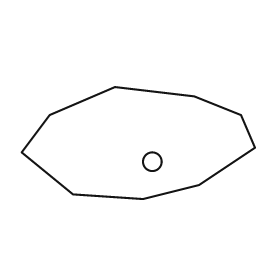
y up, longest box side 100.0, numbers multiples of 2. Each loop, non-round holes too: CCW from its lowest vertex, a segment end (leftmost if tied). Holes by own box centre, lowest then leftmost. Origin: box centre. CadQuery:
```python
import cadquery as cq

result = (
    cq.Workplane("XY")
    .moveTo(2.0, -24.0)
    .lineTo(26.0, -18.0)
    .lineTo(50.0, -2.0)
    .lineTo(44.0, 12.0)
    .lineTo(24.0, 20.0)
    .lineTo(-10.0, 24.0)
    .lineTo(-38.0, 12.0)
    .lineTo(-50.0, -4.0)
    .lineTo(-28.0, -22.0)
    .close()
    .moveTo(6.0, -8.0)
    .circle(4.0)
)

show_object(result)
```